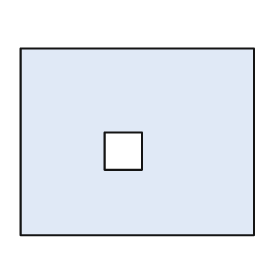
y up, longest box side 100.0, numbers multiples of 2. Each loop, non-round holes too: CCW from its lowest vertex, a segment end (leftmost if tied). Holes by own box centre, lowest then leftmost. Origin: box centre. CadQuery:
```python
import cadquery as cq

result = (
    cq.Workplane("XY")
    .moveTo(-50.0, -40.0)
    .lineTo(50.0, -40.0)
    .lineTo(50.0, 40.0)
    .lineTo(-50.0, 40.0)
    .close()
    .moveTo(-14.0, -12.0)
    .lineTo(2.0, -12.0)
    .lineTo(2.0, 4.0)
    .lineTo(-14.0, 4.0)
    .close()
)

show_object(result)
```